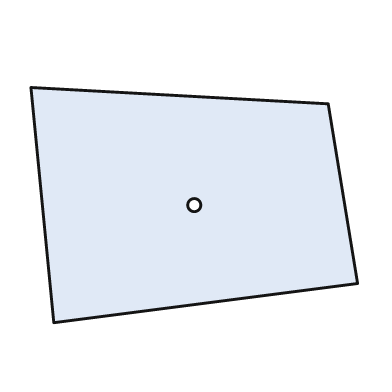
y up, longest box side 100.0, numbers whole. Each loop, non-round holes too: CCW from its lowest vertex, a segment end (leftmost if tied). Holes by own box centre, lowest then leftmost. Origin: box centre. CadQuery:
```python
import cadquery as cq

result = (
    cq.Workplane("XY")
    .moveTo(-43.0, -36.0)
    .lineTo(50.0, -24.0)
    .lineTo(41.0, 31.0)
    .lineTo(-50.0, 36.0)
    .close()
    .moveTo(0.0, 0.0)
    .circle(2.0)
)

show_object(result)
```